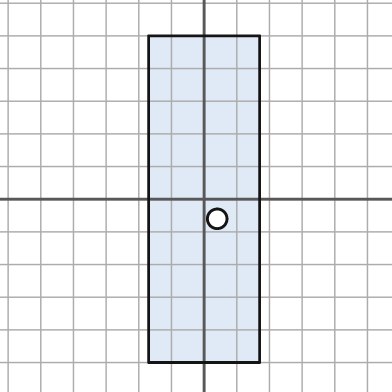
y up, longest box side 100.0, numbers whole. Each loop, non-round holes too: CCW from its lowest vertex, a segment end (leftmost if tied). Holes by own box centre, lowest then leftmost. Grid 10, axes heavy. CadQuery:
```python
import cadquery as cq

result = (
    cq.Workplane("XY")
    .moveTo(-17.0, -50.0)
    .lineTo(17.0, -50.0)
    .lineTo(17.0, 50.0)
    .lineTo(-17.0, 50.0)
    .close()
    .moveTo(4.0, -6.0)
    .circle(3.0)
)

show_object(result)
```